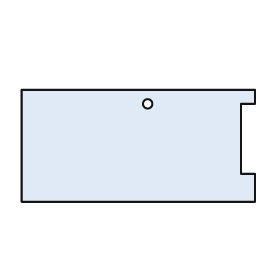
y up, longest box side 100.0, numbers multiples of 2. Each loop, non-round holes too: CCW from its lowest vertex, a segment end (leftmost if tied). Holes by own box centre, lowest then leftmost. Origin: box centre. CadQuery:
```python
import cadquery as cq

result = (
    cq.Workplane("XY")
    .moveTo(-50.0, -24.0)
    .lineTo(50.0, -24.0)
    .lineTo(50.0, -12.0)
    .lineTo(44.0, -12.0)
    .lineTo(44.0, 18.0)
    .lineTo(50.0, 18.0)
    .lineTo(50.0, 24.0)
    .lineTo(-50.0, 24.0)
    .close()
    .moveTo(4.0, 18.0)
    .circle(2.0)
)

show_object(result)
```